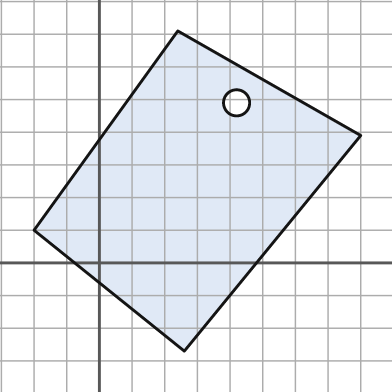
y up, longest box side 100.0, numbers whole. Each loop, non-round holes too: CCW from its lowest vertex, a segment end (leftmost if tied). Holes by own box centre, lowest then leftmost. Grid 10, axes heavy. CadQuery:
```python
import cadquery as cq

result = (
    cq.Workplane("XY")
    .moveTo(26.0, -27.0)
    .lineTo(80.0, 39.0)
    .lineTo(24.0, 71.0)
    .lineTo(-20.0, 10.0)
    .close()
    .moveTo(42.0, 49.0)
    .circle(4.0)
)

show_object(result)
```